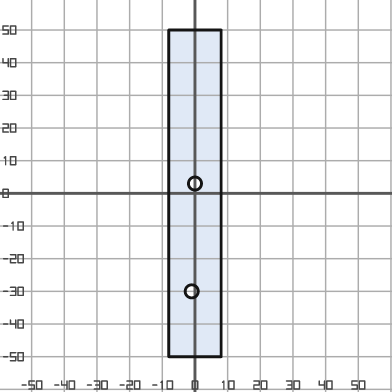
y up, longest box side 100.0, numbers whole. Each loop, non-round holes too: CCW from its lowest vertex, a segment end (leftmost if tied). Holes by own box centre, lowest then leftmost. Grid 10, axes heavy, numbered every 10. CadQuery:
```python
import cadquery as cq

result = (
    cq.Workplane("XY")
    .moveTo(-8.0, -50.0)
    .lineTo(8.0, -50.0)
    .lineTo(8.0, 50.0)
    .lineTo(-8.0, 50.0)
    .close()
    .moveTo(-1.0, -30.0)
    .circle(2.0)
    .moveTo(0.0, 3.0)
    .circle(2.0)
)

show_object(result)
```